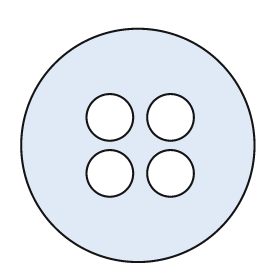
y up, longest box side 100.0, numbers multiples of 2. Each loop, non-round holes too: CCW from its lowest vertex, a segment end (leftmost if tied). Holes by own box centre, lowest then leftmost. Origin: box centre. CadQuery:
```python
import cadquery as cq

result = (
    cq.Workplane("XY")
    .moveTo(0.0, 0.0)
    .circle(50.0)
    .moveTo(-12.0, -12.0)
    .circle(10.0)
    .moveTo(14.0, -12.0)
    .circle(10.0)
    .moveTo(-12.0, 12.0)
    .circle(10.0)
    .moveTo(14.0, 12.0)
    .circle(10.0)
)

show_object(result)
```